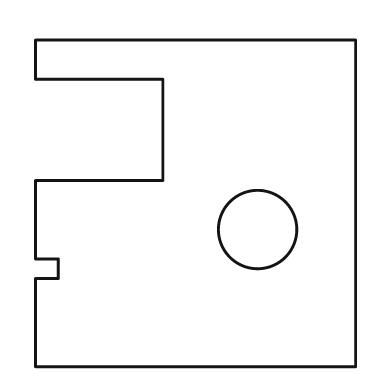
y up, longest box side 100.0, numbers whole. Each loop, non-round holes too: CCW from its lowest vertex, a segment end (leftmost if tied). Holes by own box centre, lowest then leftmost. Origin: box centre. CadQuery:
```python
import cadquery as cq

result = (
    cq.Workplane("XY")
    .moveTo(-49.0, -50.0)
    .lineTo(49.0, -50.0)
    .lineTo(49.0, 50.0)
    .lineTo(-49.0, 50.0)
    .lineTo(-49.0, 38.0)
    .lineTo(-10.0, 38.0)
    .lineTo(-10.0, 7.0)
    .lineTo(-49.0, 7.0)
    .lineTo(-49.0, -17.0)
    .lineTo(-42.0, -17.0)
    .lineTo(-42.0, -23.0)
    .lineTo(-49.0, -23.0)
    .close()
    .moveTo(19.0, -8.0)
    .circle(12.0)
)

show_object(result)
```